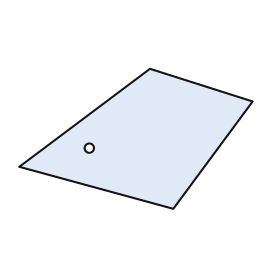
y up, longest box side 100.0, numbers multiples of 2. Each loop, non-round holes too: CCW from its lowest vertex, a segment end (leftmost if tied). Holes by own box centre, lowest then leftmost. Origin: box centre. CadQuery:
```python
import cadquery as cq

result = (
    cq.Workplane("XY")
    .moveTo(16.0, -30.0)
    .lineTo(50.0, 16.0)
    .lineTo(6.0, 30.0)
    .lineTo(-50.0, -12.0)
    .close()
    .moveTo(-20.0, -4.0)
    .circle(2.0)
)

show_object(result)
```